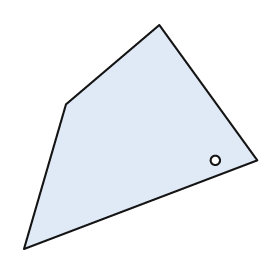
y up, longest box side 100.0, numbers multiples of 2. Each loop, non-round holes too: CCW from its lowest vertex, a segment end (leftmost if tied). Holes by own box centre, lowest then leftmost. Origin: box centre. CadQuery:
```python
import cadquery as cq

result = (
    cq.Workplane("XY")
    .moveTo(-50.0, -48.0)
    .lineTo(50.0, -10.0)
    .lineTo(8.0, 48.0)
    .lineTo(-32.0, 14.0)
    .close()
    .moveTo(32.0, -10.0)
    .circle(2.0)
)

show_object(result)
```